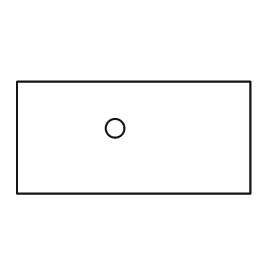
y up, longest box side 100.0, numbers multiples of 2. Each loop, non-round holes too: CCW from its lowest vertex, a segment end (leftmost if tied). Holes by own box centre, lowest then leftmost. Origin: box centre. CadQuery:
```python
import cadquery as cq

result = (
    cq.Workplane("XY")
    .moveTo(-50.0, -24.0)
    .lineTo(50.0, -24.0)
    .lineTo(50.0, 24.0)
    .lineTo(-50.0, 24.0)
    .close()
    .moveTo(-8.0, 4.0)
    .circle(4.0)
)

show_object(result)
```